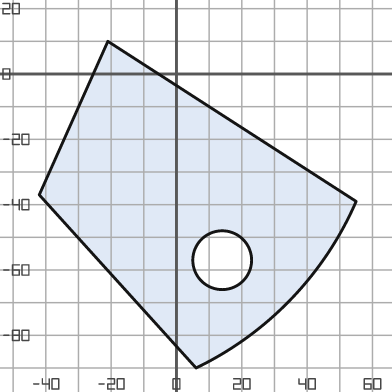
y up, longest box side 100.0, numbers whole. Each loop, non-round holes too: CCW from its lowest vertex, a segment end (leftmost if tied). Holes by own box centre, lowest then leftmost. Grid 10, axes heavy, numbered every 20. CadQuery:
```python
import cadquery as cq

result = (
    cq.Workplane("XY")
    .moveTo(6.0, -90.0)
    .threePointArc((35.0, -69.0), (55.0, -39.0))
    .lineTo(-21.0, 10.0)
    .lineTo(-42.0, -37.0)
    .close()
    .moveTo(14.0, -57.0)
    .circle(9.0)
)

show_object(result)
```